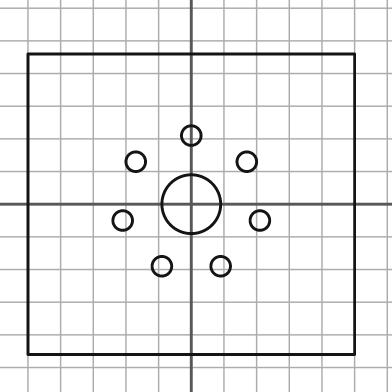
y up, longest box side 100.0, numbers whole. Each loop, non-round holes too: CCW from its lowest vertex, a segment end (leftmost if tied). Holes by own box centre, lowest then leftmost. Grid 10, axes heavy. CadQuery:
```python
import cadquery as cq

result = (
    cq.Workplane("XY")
    .moveTo(-50.0, -46.0)
    .lineTo(50.0, -46.0)
    .lineTo(50.0, 46.0)
    .lineTo(-50.0, 46.0)
    .close()
    .moveTo(-9.0, -19.0)
    .circle(3.0)
    .moveTo(9.0, -19.0)
    .circle(3.0)
    .moveTo(-21.0, -5.0)
    .circle(3.0)
    .moveTo(21.0, -5.0)
    .circle(3.0)
    .moveTo(0.0, 0.0)
    .circle(9.0)
    .moveTo(-17.0, 13.0)
    .circle(3.0)
    .moveTo(17.0, 13.0)
    .circle(3.0)
    .moveTo(0.0, 21.0)
    .circle(3.0)
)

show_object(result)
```